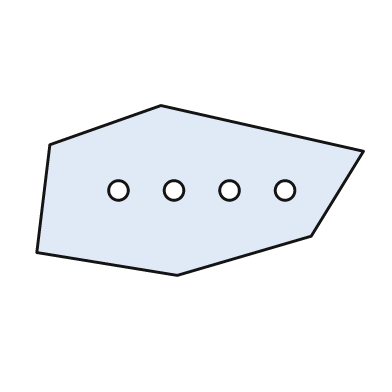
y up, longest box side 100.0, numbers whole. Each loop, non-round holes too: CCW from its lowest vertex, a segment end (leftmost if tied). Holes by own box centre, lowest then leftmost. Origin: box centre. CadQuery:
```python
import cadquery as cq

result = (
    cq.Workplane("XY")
    .moveTo(-7.0, -26.0)
    .lineTo(34.0, -14.0)
    .lineTo(50.0, 12.0)
    .lineTo(-12.0, 26.0)
    .lineTo(-46.0, 14.0)
    .lineTo(-50.0, -19.0)
    .close()
    .moveTo(-25.0, 0.0)
    .circle(3.0)
    .moveTo(-8.0, 0.0)
    .circle(3.0)
    .moveTo(9.0, 0.0)
    .circle(3.0)
    .moveTo(26.0, 0.0)
    .circle(3.0)
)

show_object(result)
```